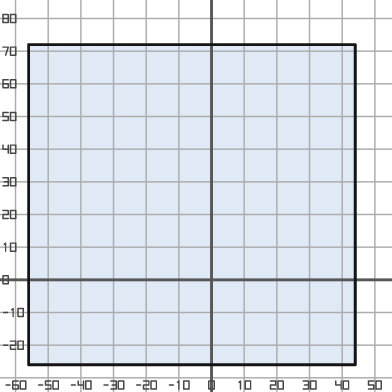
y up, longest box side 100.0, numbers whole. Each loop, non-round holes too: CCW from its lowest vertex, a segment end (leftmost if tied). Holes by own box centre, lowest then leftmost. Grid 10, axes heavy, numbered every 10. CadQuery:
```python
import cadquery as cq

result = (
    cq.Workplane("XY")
    .moveTo(-56.0, -26.0)
    .lineTo(44.0, -26.0)
    .lineTo(44.0, 72.0)
    .lineTo(-56.0, 72.0)
    .close()
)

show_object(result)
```